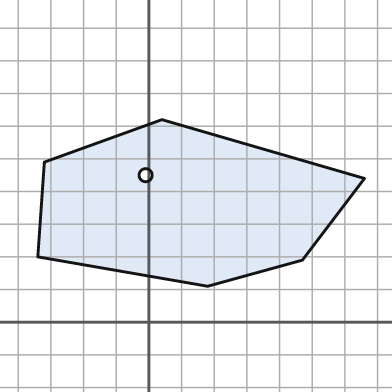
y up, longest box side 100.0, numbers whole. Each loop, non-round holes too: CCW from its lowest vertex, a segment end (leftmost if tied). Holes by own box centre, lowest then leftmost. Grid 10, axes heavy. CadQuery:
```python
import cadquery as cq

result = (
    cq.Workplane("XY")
    .moveTo(18.0, 11.0)
    .lineTo(47.0, 19.0)
    .lineTo(66.0, 44.0)
    .lineTo(4.0, 62.0)
    .lineTo(-32.0, 49.0)
    .lineTo(-34.0, 20.0)
    .close()
    .moveTo(-1.0, 45.0)
    .circle(2.0)
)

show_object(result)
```